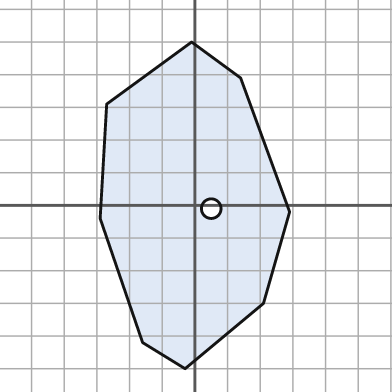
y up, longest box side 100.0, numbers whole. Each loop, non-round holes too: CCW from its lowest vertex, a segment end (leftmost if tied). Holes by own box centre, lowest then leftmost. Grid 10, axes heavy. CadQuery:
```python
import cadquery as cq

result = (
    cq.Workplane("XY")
    .moveTo(-3.0, -50.0)
    .lineTo(21.0, -30.0)
    .lineTo(29.0, -2.0)
    .lineTo(14.0, 39.0)
    .lineTo(-1.0, 50.0)
    .lineTo(-27.0, 31.0)
    .lineTo(-29.0, -4.0)
    .lineTo(-16.0, -42.0)
    .close()
    .moveTo(5.0, -1.0)
    .circle(3.0)
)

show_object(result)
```